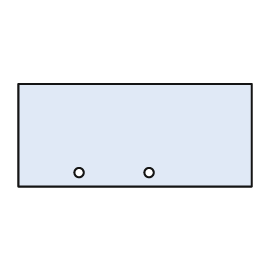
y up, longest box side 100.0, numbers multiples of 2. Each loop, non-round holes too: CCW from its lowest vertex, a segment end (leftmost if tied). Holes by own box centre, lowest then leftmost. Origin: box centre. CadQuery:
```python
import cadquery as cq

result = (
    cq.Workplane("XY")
    .moveTo(-50.0, -22.0)
    .lineTo(50.0, -22.0)
    .lineTo(50.0, 22.0)
    .lineTo(-50.0, 22.0)
    .close()
    .moveTo(-24.0, -16.0)
    .circle(2.0)
    .moveTo(6.0, -16.0)
    .circle(2.0)
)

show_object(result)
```